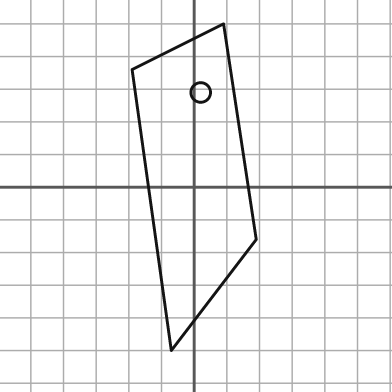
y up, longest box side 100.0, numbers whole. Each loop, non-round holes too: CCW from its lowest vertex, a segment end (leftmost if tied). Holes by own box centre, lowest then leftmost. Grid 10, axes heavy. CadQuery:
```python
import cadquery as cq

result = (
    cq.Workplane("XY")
    .moveTo(-7.0, -50.0)
    .lineTo(19.0, -16.0)
    .lineTo(9.0, 50.0)
    .lineTo(-19.0, 36.0)
    .close()
    .moveTo(2.0, 29.0)
    .circle(3.0)
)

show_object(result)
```